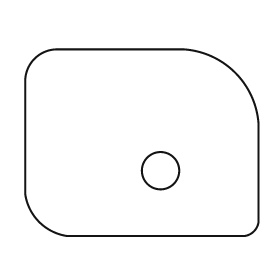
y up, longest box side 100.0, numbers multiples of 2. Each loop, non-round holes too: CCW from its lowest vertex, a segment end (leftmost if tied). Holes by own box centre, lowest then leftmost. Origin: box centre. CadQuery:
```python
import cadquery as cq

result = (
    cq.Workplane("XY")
    .moveTo(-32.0, -40.0)
    .lineTo(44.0, -40.0)
    .threePointArc((48.0, -38.0), (50.0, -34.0))
    .lineTo(50.0, 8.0)
    .threePointArc((40.0, 30.0), (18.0, 40.0))
    .lineTo(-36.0, 40.0)
    .threePointArc((-46.0, 36.0), (-50.0, 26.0))
    .lineTo(-50.0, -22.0)
    .threePointArc((-44.0, -34.0), (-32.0, -40.0))
    .close()
    .moveTo(8.0, -12.0)
    .circle(8.0)
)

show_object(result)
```